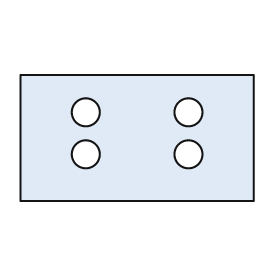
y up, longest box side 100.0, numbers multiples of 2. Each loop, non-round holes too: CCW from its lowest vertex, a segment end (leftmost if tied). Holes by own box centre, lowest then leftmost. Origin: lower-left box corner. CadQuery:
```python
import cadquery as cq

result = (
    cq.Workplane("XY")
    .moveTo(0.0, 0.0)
    .lineTo(100.0, 0.0)
    .lineTo(100.0, 54.0)
    .lineTo(0.0, 54.0)
    .close()
    .moveTo(28.0, 20.0)
    .circle(6.0)
    .moveTo(72.0, 20.0)
    .circle(6.0)
    .moveTo(28.0, 38.0)
    .circle(6.0)
    .moveTo(72.0, 38.0)
    .circle(6.0)
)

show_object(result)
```